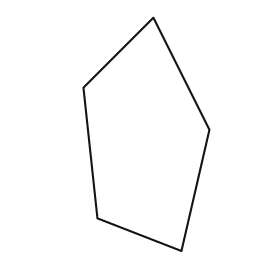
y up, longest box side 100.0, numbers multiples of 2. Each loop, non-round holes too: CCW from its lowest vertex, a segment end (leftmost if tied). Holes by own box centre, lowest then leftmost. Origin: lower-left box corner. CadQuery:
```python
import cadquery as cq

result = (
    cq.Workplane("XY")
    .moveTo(42.0, 0.0)
    .lineTo(54.0, 52.0)
    .lineTo(30.0, 100.0)
    .lineTo(0.0, 70.0)
    .lineTo(6.0, 14.0)
    .close()
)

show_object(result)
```